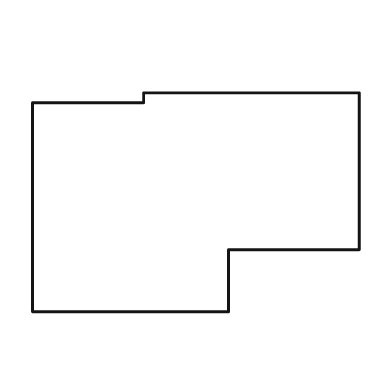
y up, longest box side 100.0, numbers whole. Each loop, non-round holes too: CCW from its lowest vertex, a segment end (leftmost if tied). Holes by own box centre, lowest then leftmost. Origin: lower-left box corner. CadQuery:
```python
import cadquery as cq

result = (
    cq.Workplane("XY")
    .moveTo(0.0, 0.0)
    .lineTo(60.0, 0.0)
    .lineTo(60.0, 19.0)
    .lineTo(100.0, 19.0)
    .lineTo(100.0, 67.0)
    .lineTo(34.0, 67.0)
    .lineTo(34.0, 64.0)
    .lineTo(0.0, 64.0)
    .close()
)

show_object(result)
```